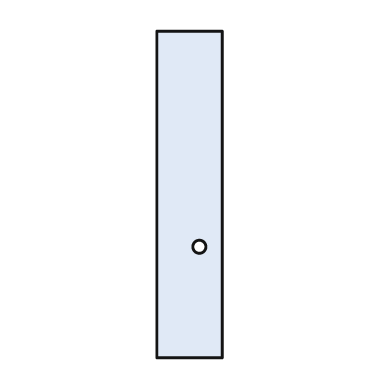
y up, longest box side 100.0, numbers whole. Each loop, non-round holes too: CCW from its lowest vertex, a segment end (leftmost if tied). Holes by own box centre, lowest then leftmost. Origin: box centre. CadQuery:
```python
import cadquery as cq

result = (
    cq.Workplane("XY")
    .moveTo(-10.0, -50.0)
    .lineTo(10.0, -50.0)
    .lineTo(10.0, 50.0)
    .lineTo(-10.0, 50.0)
    .close()
    .moveTo(3.0, -16.0)
    .circle(2.0)
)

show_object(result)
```